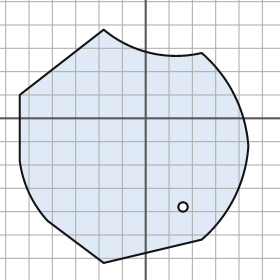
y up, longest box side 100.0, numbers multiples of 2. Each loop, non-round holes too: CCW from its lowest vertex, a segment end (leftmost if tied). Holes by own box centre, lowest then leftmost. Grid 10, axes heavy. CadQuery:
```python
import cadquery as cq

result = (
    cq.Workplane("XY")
    .moveTo(-18.0, -62.0)
    .lineTo(24.0, -52.0)
    .threePointArc((38.0, -34.0), (44.0, -12.0))
    .threePointArc((38.0, 10.0), (24.0, 28.0))
    .threePointArc((2.0, 28.0), (-18.0, 38.0))
    .lineTo(-54.0, 10.0)
    .lineTo(-54.0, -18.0)
    .threePointArc((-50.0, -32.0), (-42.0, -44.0))
    .close()
    .moveTo(16.0, -38.0)
    .circle(2.0)
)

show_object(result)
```